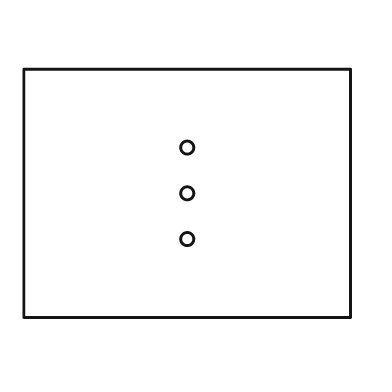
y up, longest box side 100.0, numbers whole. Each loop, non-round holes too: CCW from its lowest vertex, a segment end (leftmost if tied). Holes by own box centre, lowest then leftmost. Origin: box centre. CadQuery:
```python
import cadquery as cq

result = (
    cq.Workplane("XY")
    .moveTo(-50.0, -38.0)
    .lineTo(50.0, -38.0)
    .lineTo(50.0, 38.0)
    .lineTo(-50.0, 38.0)
    .close()
    .moveTo(0.0, -14.0)
    .circle(2.0)
    .moveTo(0.0, 0.0)
    .circle(2.0)
    .moveTo(0.0, 14.0)
    .circle(2.0)
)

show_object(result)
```